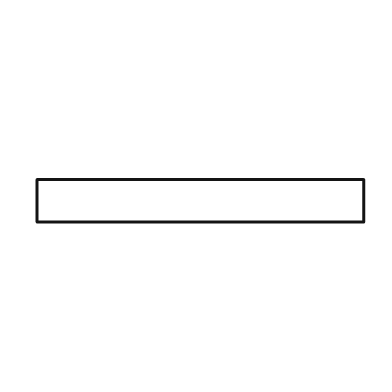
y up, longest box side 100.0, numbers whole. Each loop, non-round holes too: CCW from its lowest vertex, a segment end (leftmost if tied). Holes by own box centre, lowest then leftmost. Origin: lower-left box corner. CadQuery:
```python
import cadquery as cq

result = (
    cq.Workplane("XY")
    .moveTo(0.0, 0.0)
    .lineTo(100.0, 0.0)
    .lineTo(100.0, 13.0)
    .lineTo(0.0, 13.0)
    .close()
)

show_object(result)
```